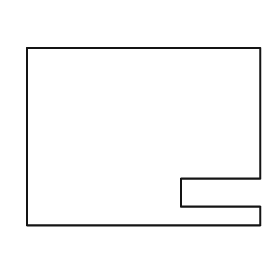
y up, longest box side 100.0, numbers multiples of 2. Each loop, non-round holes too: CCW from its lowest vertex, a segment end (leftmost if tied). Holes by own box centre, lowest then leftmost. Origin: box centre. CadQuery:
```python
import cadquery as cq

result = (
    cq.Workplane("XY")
    .moveTo(-50.0, -38.0)
    .lineTo(50.0, -38.0)
    .lineTo(50.0, -30.0)
    .lineTo(16.0, -30.0)
    .lineTo(16.0, -18.0)
    .lineTo(50.0, -18.0)
    .lineTo(50.0, 38.0)
    .lineTo(-50.0, 38.0)
    .close()
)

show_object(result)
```